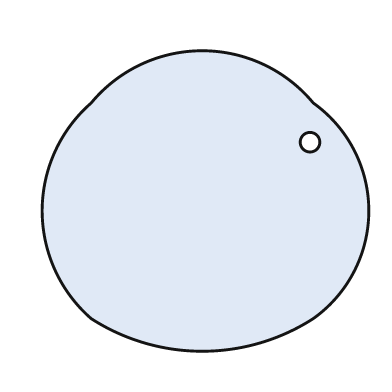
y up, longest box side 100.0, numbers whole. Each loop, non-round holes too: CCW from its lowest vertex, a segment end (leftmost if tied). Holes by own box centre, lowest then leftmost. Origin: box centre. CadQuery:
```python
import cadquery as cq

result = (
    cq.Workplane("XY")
    .moveTo(-35.0, -36.0)
    .threePointArc((-1.0, -46.0), (33.0, -36.0))
    .threePointArc((50.0, -3.0), (33.0, 30.0))
    .threePointArc((-1.0, 46.0), (-35.0, 30.0))
    .threePointArc((-50.0, -3.0), (-35.0, -36.0))
    .close()
    .moveTo(32.0, 18.0)
    .circle(3.0)
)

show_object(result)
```